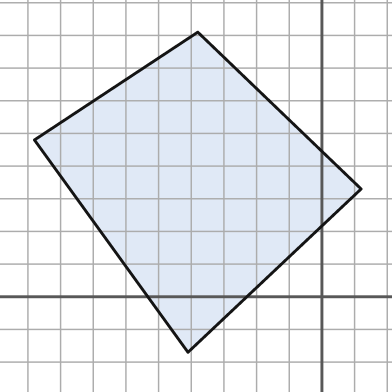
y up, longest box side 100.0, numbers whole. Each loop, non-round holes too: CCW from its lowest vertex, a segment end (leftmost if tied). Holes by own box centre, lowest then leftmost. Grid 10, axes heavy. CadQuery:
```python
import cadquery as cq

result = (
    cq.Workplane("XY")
    .moveTo(-41.0, -17.0)
    .lineTo(12.0, 33.0)
    .lineTo(-38.0, 81.0)
    .lineTo(-88.0, 48.0)
    .close()
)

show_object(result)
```